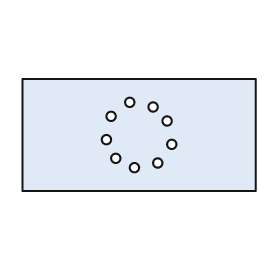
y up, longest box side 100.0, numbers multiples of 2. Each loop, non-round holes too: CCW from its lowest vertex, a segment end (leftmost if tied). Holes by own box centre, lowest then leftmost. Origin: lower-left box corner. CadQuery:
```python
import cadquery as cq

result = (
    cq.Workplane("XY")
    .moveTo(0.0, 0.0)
    .lineTo(100.0, 0.0)
    .lineTo(100.0, 48.0)
    .lineTo(0.0, 48.0)
    .close()
    .moveTo(48.0, 10.0)
    .circle(2.0)
    .moveTo(58.0, 12.0)
    .circle(2.0)
    .moveTo(40.0, 14.0)
    .circle(2.0)
    .moveTo(64.0, 20.0)
    .circle(2.0)
    .moveTo(36.0, 22.0)
    .circle(2.0)
    .moveTo(62.0, 30.0)
    .circle(2.0)
    .moveTo(38.0, 32.0)
    .circle(2.0)
    .moveTo(56.0, 36.0)
    .circle(2.0)
    .moveTo(46.0, 38.0)
    .circle(2.0)
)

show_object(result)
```